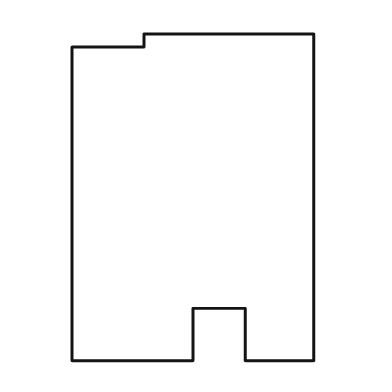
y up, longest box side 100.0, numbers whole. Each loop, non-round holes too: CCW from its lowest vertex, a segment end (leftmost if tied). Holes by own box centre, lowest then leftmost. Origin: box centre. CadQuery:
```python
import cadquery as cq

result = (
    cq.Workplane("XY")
    .moveTo(-37.0, -50.0)
    .lineTo(0.0, -50.0)
    .lineTo(0.0, -34.0)
    .lineTo(16.0, -34.0)
    .lineTo(16.0, -50.0)
    .lineTo(37.0, -50.0)
    .lineTo(37.0, 50.0)
    .lineTo(-15.0, 50.0)
    .lineTo(-15.0, 46.0)
    .lineTo(-37.0, 46.0)
    .close()
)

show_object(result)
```